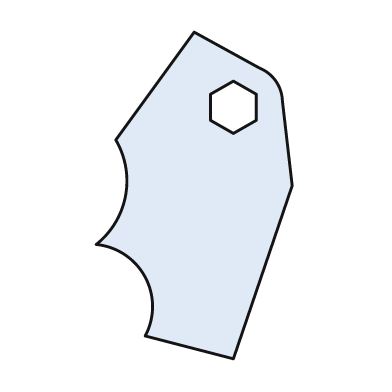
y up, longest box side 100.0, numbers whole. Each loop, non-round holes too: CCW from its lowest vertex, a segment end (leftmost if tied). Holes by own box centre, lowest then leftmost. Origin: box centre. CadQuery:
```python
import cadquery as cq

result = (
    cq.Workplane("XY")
    .moveTo(12.0, -50.0)
    .lineTo(30.0, 3.0)
    .lineTo(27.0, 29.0)
    .threePointArc((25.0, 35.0), (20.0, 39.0))
    .lineTo(0.0, 50.0)
    .lineTo(-24.0, 17.0)
    .threePointArc((-21.0, 0.0), (-30.0, -15.0))
    .threePointArc((-15.0, -25.0), (-15.0, -43.0))
    .close()
    .moveTo(12.0, 19.0)
    .lineTo(19.0, 23.0)
    .lineTo(19.0, 31.0)
    .lineTo(12.0, 35.0)
    .lineTo(5.0, 31.0)
    .lineTo(5.0, 23.0)
    .close()
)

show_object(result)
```